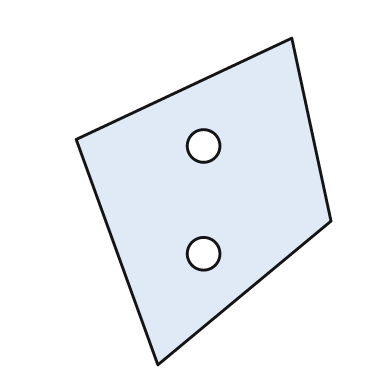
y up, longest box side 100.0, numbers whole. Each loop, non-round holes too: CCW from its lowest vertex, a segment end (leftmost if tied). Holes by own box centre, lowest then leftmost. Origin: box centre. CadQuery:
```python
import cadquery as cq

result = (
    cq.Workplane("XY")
    .moveTo(-14.0, -50.0)
    .lineTo(39.0, -6.0)
    .lineTo(27.0, 50.0)
    .lineTo(-39.0, 19.0)
    .close()
    .moveTo(0.0, -16.0)
    .circle(5.0)
    .moveTo(0.0, 17.0)
    .circle(5.0)
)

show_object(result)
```